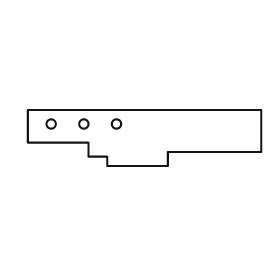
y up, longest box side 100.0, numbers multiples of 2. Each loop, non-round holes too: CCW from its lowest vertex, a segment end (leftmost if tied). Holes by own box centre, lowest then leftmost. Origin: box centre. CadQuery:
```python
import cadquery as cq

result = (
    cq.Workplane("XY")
    .moveTo(-16.0, -12.0)
    .lineTo(10.0, -12.0)
    .lineTo(10.0, -6.0)
    .lineTo(50.0, -6.0)
    .lineTo(50.0, 12.0)
    .lineTo(-50.0, 12.0)
    .lineTo(-50.0, -2.0)
    .lineTo(-24.0, -2.0)
    .lineTo(-24.0, -8.0)
    .lineTo(-16.0, -8.0)
    .close()
    .moveTo(-40.0, 6.0)
    .circle(2.0)
    .moveTo(-26.0, 6.0)
    .circle(2.0)
    .moveTo(-12.0, 6.0)
    .circle(2.0)
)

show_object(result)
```